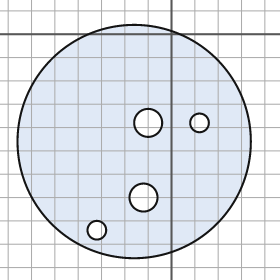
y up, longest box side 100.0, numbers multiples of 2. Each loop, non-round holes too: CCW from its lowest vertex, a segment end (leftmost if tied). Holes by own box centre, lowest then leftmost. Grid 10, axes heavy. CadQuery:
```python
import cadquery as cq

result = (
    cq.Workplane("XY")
    .moveTo(-16.0, -46.0)
    .circle(50.0)
    .moveTo(-32.0, -84.0)
    .circle(4.0)
    .moveTo(-12.0, -70.0)
    .circle(6.0)
    .moveTo(-10.0, -38.0)
    .circle(6.0)
    .moveTo(12.0, -38.0)
    .circle(4.0)
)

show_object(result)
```